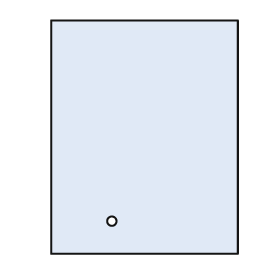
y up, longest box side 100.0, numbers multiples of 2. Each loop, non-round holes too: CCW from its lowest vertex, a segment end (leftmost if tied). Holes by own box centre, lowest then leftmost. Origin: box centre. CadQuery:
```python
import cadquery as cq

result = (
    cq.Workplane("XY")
    .moveTo(-40.0, -50.0)
    .lineTo(40.0, -50.0)
    .lineTo(40.0, 50.0)
    .lineTo(-40.0, 50.0)
    .close()
    .moveTo(-14.0, -36.0)
    .circle(2.0)
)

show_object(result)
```